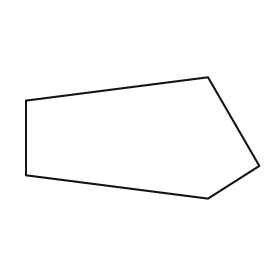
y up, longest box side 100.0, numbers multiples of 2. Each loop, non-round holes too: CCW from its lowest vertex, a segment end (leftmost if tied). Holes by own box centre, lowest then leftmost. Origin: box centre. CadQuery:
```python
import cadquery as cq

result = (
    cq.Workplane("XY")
    .moveTo(28.0, -26.0)
    .lineTo(50.0, -12.0)
    .lineTo(28.0, 26.0)
    .lineTo(-50.0, 16.0)
    .lineTo(-50.0, -16.0)
    .close()
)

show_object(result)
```